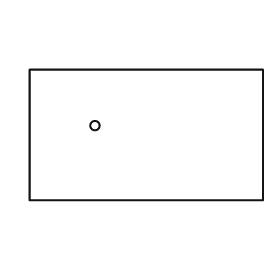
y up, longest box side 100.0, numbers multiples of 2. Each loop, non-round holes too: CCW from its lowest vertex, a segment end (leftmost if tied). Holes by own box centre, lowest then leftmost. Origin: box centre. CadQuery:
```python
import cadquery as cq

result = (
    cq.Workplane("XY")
    .moveTo(-50.0, -28.0)
    .lineTo(50.0, -28.0)
    .lineTo(50.0, 28.0)
    .lineTo(-50.0, 28.0)
    .close()
    .moveTo(-22.0, 4.0)
    .circle(2.0)
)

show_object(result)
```